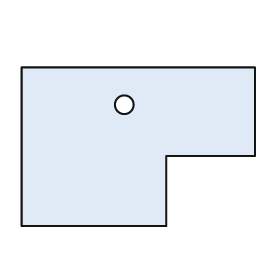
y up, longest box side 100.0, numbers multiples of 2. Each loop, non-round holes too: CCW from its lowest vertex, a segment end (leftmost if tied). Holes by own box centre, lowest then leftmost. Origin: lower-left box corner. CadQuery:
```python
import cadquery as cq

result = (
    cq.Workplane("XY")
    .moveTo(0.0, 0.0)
    .lineTo(62.0, 0.0)
    .lineTo(62.0, 30.0)
    .lineTo(100.0, 30.0)
    .lineTo(100.0, 68.0)
    .lineTo(0.0, 68.0)
    .close()
    .moveTo(44.0, 52.0)
    .circle(4.0)
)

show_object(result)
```